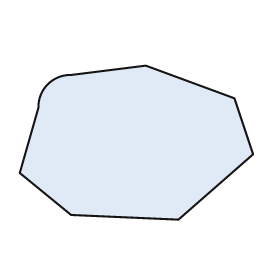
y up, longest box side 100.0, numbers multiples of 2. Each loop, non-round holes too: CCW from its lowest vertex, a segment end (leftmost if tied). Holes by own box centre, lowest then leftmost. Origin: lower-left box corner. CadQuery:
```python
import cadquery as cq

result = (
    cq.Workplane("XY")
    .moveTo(68.0, 0.0)
    .lineTo(100.0, 28.0)
    .lineTo(92.0, 52.0)
    .lineTo(54.0, 66.0)
    .lineTo(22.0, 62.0)
    .threePointArc((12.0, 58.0), (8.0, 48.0))
    .lineTo(0.0, 20.0)
    .lineTo(22.0, 2.0)
    .close()
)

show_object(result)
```